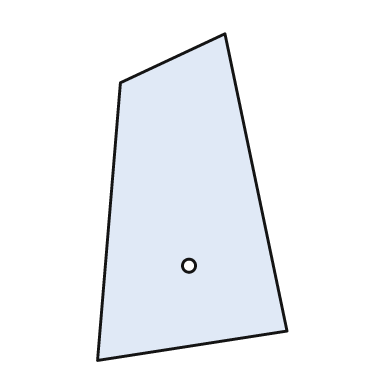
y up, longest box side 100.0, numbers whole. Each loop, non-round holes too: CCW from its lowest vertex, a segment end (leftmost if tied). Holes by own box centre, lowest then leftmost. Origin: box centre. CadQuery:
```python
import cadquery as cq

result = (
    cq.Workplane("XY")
    .moveTo(-29.0, -50.0)
    .lineTo(29.0, -41.0)
    .lineTo(10.0, 50.0)
    .lineTo(-22.0, 35.0)
    .close()
    .moveTo(-1.0, -21.0)
    .circle(2.0)
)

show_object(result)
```